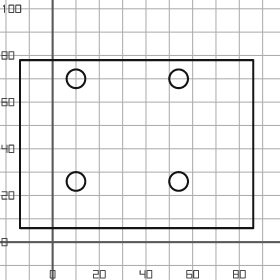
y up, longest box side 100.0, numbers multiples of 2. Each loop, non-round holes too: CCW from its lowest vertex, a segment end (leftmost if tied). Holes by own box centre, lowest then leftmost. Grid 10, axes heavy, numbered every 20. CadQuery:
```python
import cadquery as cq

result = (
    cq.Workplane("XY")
    .moveTo(-14.0, 6.0)
    .lineTo(86.0, 6.0)
    .lineTo(86.0, 78.0)
    .lineTo(-14.0, 78.0)
    .close()
    .moveTo(10.0, 26.0)
    .circle(4.0)
    .moveTo(54.0, 26.0)
    .circle(4.0)
    .moveTo(10.0, 70.0)
    .circle(4.0)
    .moveTo(54.0, 70.0)
    .circle(4.0)
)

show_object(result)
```